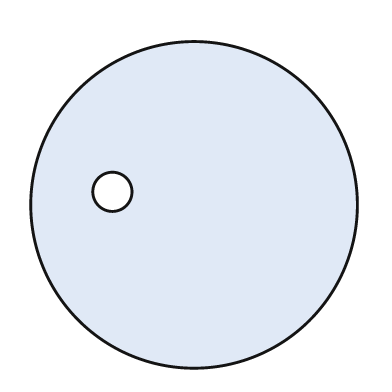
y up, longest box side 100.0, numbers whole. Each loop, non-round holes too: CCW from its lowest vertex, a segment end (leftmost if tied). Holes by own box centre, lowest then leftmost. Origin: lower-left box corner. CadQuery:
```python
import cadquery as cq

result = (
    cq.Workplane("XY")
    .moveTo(50.0, 50.0)
    .circle(50.0)
    .moveTo(25.0, 54.0)
    .circle(6.0)
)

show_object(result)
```